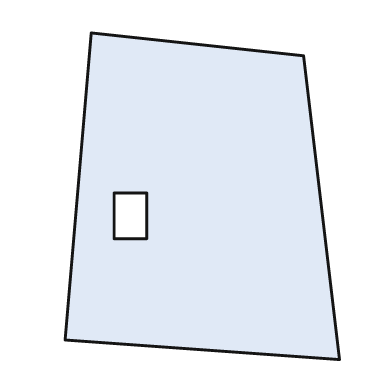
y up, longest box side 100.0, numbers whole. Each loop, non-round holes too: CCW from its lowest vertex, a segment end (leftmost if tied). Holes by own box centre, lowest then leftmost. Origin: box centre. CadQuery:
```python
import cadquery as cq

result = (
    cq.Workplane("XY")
    .moveTo(42.0, -50.0)
    .lineTo(31.0, 43.0)
    .lineTo(-34.0, 50.0)
    .lineTo(-42.0, -44.0)
    .close()
    .moveTo(-27.0, -13.0)
    .lineTo(-17.0, -13.0)
    .lineTo(-17.0, 1.0)
    .lineTo(-27.0, 1.0)
    .close()
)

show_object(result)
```